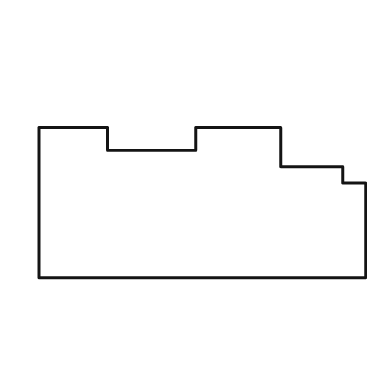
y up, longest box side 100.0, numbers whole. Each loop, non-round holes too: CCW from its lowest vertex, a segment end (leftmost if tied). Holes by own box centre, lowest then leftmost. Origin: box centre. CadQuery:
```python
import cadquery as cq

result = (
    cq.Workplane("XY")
    .moveTo(-50.0, -23.0)
    .lineTo(50.0, -23.0)
    .lineTo(50.0, 6.0)
    .lineTo(43.0, 6.0)
    .lineTo(43.0, 11.0)
    .lineTo(24.0, 11.0)
    .lineTo(24.0, 23.0)
    .lineTo(-2.0, 23.0)
    .lineTo(-2.0, 16.0)
    .lineTo(-29.0, 16.0)
    .lineTo(-29.0, 23.0)
    .lineTo(-50.0, 23.0)
    .close()
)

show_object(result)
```